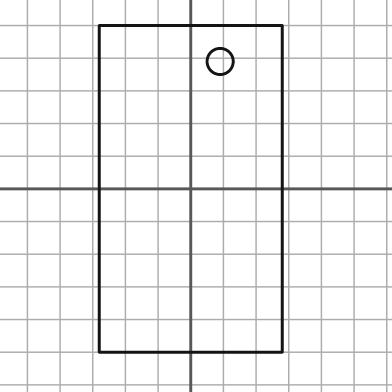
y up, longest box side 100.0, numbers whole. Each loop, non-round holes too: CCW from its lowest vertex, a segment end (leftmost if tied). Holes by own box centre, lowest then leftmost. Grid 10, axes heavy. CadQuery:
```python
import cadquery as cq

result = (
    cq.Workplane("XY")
    .moveTo(-28.0, -50.0)
    .lineTo(28.0, -50.0)
    .lineTo(28.0, 50.0)
    .lineTo(-28.0, 50.0)
    .close()
    .moveTo(9.0, 39.0)
    .circle(4.0)
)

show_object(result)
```